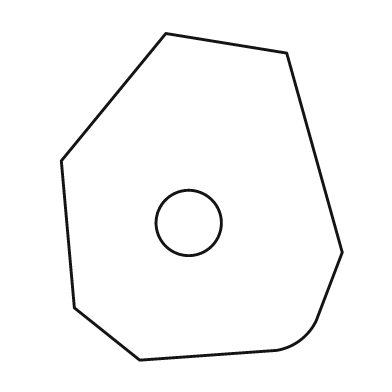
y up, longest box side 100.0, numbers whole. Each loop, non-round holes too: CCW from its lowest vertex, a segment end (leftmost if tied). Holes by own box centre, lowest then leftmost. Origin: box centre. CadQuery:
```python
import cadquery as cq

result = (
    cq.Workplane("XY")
    .moveTo(-19.0, -50.0)
    .lineTo(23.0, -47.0)
    .threePointArc((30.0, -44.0), (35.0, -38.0))
    .lineTo(43.0, -17.0)
    .lineTo(26.0, 44.0)
    .lineTo(-11.0, 50.0)
    .lineTo(-43.0, 11.0)
    .lineTo(-39.0, -34.0)
    .close()
    .moveTo(-4.0, -8.0)
    .circle(10.0)
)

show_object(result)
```